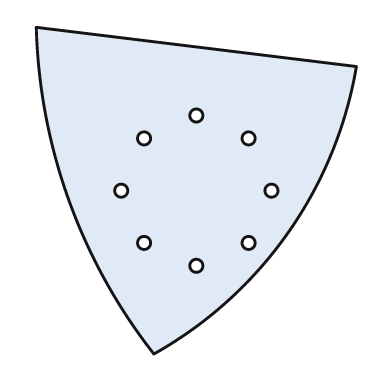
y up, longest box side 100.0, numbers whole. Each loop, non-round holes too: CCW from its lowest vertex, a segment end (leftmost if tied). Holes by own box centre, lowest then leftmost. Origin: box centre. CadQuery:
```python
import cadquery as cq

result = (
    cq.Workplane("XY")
    .moveTo(-13.0, -50.0)
    .threePointArc((28.0, -13.0), (49.0, 38.0))
    .lineTo(-49.0, 50.0)
    .threePointArc((-39.0, -3.0), (-13.0, -50.0))
    .close()
    .moveTo(0.0, -23.0)
    .circle(2.0)
    .moveTo(-16.0, -16.0)
    .circle(2.0)
    .moveTo(16.0, -16.0)
    .circle(2.0)
    .moveTo(-23.0, 0.0)
    .circle(2.0)
    .moveTo(23.0, 0.0)
    .circle(2.0)
    .moveTo(-16.0, 16.0)
    .circle(2.0)
    .moveTo(16.0, 16.0)
    .circle(2.0)
    .moveTo(0.0, 23.0)
    .circle(2.0)
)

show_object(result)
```